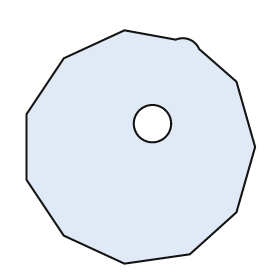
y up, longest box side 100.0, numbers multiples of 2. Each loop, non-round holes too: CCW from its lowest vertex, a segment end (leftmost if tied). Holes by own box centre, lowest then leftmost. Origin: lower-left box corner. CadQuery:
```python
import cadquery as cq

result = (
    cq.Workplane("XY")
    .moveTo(42.0, 0.0)
    .lineTo(70.0, 4.0)
    .lineTo(90.0, 22.0)
    .lineTo(98.0, 50.0)
    .lineTo(90.0, 78.0)
    .lineTo(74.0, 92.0)
    .threePointArc((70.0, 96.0), (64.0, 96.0))
    .lineTo(42.0, 100.0)
    .lineTo(16.0, 88.0)
    .lineTo(0.0, 64.0)
    .lineTo(0.0, 36.0)
    .lineTo(16.0, 12.0)
    .close()
    .moveTo(54.0, 60.0)
    .circle(8.0)
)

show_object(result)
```